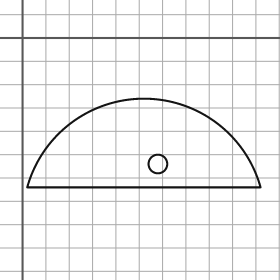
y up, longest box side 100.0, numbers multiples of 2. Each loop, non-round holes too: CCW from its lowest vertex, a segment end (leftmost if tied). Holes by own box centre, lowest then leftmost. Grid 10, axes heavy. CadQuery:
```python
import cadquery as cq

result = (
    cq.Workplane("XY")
    .moveTo(2.0, -64.0)
    .lineTo(102.0, -64.0)
    .threePointArc((52.0, -26.0), (2.0, -64.0))
    .close()
    .moveTo(58.0, -54.0)
    .circle(4.0)
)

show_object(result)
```